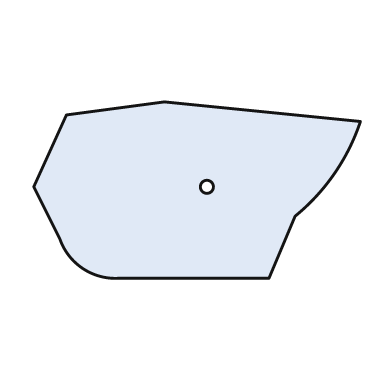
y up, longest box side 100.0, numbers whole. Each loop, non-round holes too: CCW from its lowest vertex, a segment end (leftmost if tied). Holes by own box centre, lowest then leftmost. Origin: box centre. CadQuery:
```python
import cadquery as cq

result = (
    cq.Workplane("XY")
    .moveTo(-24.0, -27.0)
    .lineTo(22.0, -27.0)
    .lineTo(30.0, -8.0)
    .threePointArc((42.0, 5.0), (50.0, 21.0))
    .lineTo(-10.0, 27.0)
    .lineTo(-40.0, 23.0)
    .lineTo(-50.0, 1.0)
    .lineTo(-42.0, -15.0)
    .threePointArc((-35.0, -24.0), (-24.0, -27.0))
    .close()
    .moveTo(3.0, 1.0)
    .circle(2.0)
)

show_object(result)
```